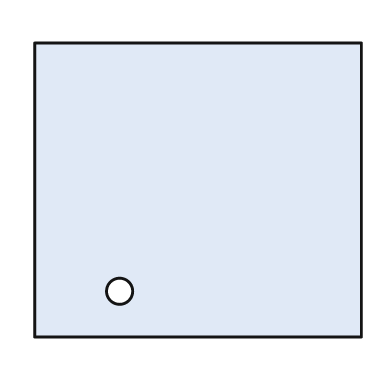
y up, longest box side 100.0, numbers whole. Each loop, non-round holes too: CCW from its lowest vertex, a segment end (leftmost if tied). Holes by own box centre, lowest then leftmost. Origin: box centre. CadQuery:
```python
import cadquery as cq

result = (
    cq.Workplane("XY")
    .moveTo(-50.0, -45.0)
    .lineTo(50.0, -45.0)
    .lineTo(50.0, 45.0)
    .lineTo(-50.0, 45.0)
    .close()
    .moveTo(-24.0, -31.0)
    .circle(4.0)
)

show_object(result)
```